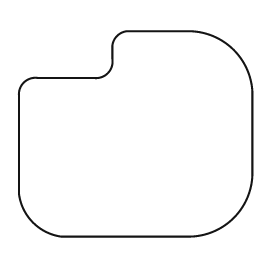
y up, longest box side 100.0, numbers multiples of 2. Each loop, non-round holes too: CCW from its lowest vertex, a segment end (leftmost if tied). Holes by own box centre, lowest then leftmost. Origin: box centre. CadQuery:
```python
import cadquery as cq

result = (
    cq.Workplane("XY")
    .moveTo(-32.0, -44.0)
    .lineTo(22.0, -44.0)
    .threePointArc((42.0, -36.0), (50.0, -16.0))
    .lineTo(50.0, 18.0)
    .threePointArc((42.0, 36.0), (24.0, 44.0))
    .lineTo(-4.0, 44.0)
    .threePointArc((-8.0, 42.0), (-10.0, 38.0))
    .lineTo(-10.0, 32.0)
    .threePointArc((-12.0, 26.0), (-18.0, 24.0))
    .lineTo(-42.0, 24.0)
    .threePointArc((-48.0, 22.0), (-50.0, 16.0))
    .lineTo(-50.0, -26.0)
    .threePointArc((-44.0, -38.0), (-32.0, -44.0))
    .close()
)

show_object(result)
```